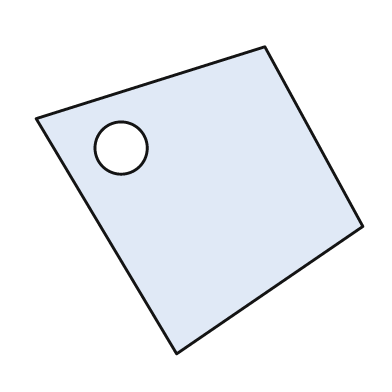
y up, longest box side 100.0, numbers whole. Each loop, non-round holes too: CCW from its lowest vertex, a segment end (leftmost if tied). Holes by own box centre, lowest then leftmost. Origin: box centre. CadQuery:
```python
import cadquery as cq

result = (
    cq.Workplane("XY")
    .moveTo(-7.0, -47.0)
    .lineTo(50.0, -8.0)
    .lineTo(20.0, 47.0)
    .lineTo(-50.0, 25.0)
    .close()
    .moveTo(-24.0, 16.0)
    .circle(8.0)
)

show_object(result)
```